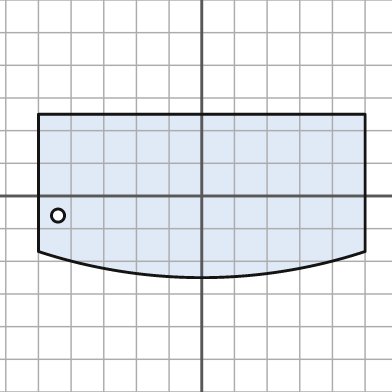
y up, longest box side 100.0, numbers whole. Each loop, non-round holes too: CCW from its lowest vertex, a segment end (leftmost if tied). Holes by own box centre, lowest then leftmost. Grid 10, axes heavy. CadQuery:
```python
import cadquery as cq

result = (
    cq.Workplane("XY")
    .moveTo(-50.0, -17.0)
    .threePointArc((0.0, -25.0), (50.0, -17.0))
    .lineTo(50.0, 25.0)
    .lineTo(-50.0, 25.0)
    .close()
    .moveTo(-44.0, -6.0)
    .circle(2.0)
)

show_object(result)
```